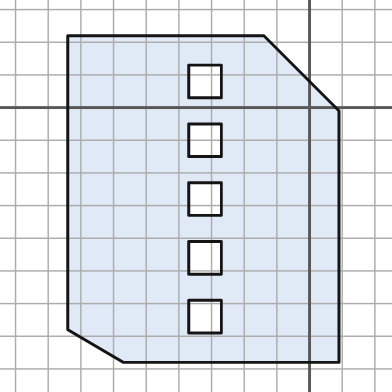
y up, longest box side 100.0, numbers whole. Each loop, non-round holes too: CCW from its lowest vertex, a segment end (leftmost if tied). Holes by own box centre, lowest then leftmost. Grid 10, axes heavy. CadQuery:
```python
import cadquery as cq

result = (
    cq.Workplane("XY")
    .moveTo(-57.0, -78.0)
    .lineTo(9.0, -78.0)
    .lineTo(9.0, -1.0)
    .lineTo(-14.0, 22.0)
    .lineTo(-74.0, 22.0)
    .lineTo(-74.0, -68.0)
    .close()
    .moveTo(-37.0, -69.0)
    .lineTo(-27.0, -69.0)
    .lineTo(-27.0, -59.0)
    .lineTo(-37.0, -59.0)
    .close()
    .moveTo(-37.0, -51.0)
    .lineTo(-27.0, -51.0)
    .lineTo(-27.0, -41.0)
    .lineTo(-37.0, -41.0)
    .close()
    .moveTo(-37.0, -33.0)
    .lineTo(-27.0, -33.0)
    .lineTo(-27.0, -23.0)
    .lineTo(-37.0, -23.0)
    .close()
    .moveTo(-37.0, -15.0)
    .lineTo(-27.0, -15.0)
    .lineTo(-27.0, -5.0)
    .lineTo(-37.0, -5.0)
    .close()
    .moveTo(-37.0, 3.0)
    .lineTo(-27.0, 3.0)
    .lineTo(-27.0, 13.0)
    .lineTo(-37.0, 13.0)
    .close()
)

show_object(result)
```